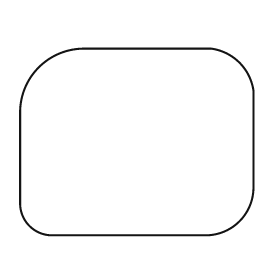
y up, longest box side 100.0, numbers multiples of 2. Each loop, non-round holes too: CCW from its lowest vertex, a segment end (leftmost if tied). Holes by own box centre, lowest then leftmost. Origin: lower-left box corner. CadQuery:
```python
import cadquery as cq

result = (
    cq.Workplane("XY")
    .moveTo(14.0, 0.0)
    .lineTo(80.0, 0.0)
    .threePointArc((94.0, 6.0), (100.0, 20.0))
    .lineTo(100.0, 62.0)
    .threePointArc((94.0, 74.0), (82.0, 80.0))
    .lineTo(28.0, 80.0)
    .threePointArc((8.0, 72.0), (0.0, 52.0))
    .lineTo(0.0, 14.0)
    .threePointArc((4.0, 4.0), (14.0, 0.0))
    .close()
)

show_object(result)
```